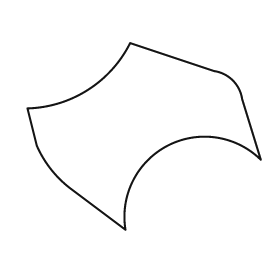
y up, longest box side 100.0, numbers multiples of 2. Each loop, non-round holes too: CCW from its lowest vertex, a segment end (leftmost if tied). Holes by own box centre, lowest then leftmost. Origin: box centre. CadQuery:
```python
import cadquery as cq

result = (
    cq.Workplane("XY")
    .moveTo(-8.0, -40.0)
    .threePointArc((10.0, -4.0), (50.0, -10.0))
    .lineTo(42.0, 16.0)
    .threePointArc((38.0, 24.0), (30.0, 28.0))
    .lineTo(-6.0, 40.0)
    .threePointArc((-24.0, 20.0), (-50.0, 12.0))
    .lineTo(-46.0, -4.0)
    .threePointArc((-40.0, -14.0), (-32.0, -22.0))
    .close()
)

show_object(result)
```